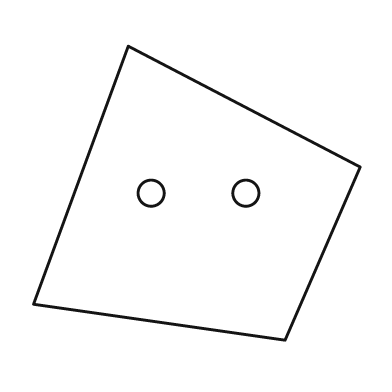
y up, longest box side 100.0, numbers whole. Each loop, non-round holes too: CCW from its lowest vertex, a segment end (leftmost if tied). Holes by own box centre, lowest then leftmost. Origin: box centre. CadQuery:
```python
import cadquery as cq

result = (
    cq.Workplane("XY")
    .moveTo(27.0, -45.0)
    .lineTo(50.0, 8.0)
    .lineTo(-21.0, 45.0)
    .lineTo(-50.0, -34.0)
    .close()
    .moveTo(-14.0, 0.0)
    .circle(4.0)
    .moveTo(15.0, 0.0)
    .circle(4.0)
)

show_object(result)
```